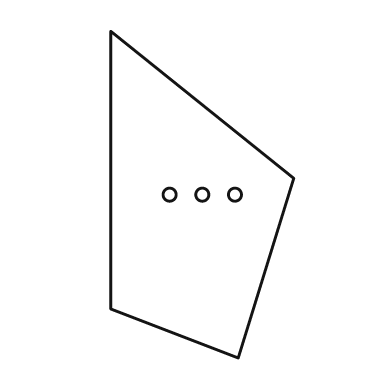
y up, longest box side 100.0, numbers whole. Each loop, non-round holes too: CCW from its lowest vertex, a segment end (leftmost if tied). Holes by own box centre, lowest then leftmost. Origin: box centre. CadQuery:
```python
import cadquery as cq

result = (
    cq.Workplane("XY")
    .moveTo(11.0, -50.0)
    .lineTo(28.0, 5.0)
    .lineTo(-28.0, 50.0)
    .lineTo(-28.0, -35.0)
    .close()
    .moveTo(-10.0, 0.0)
    .circle(2.0)
    .moveTo(0.0, 0.0)
    .circle(2.0)
    .moveTo(10.0, 0.0)
    .circle(2.0)
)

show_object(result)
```